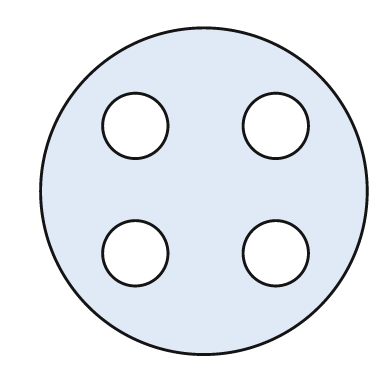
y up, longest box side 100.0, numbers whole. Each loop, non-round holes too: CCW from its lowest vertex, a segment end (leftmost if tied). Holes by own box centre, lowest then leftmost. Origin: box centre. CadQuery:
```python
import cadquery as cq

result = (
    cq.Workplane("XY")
    .moveTo(0.0, 0.0)
    .circle(50.0)
    .moveTo(-21.0, -19.0)
    .circle(10.0)
    .moveTo(22.0, -19.0)
    .circle(10.0)
    .moveTo(-21.0, 20.0)
    .circle(10.0)
    .moveTo(22.0, 20.0)
    .circle(10.0)
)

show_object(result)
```